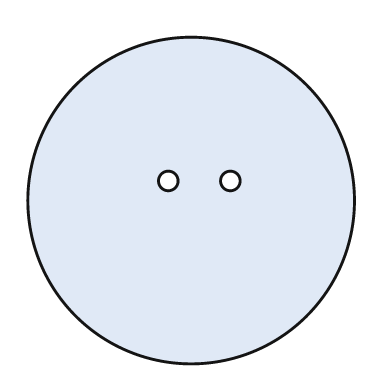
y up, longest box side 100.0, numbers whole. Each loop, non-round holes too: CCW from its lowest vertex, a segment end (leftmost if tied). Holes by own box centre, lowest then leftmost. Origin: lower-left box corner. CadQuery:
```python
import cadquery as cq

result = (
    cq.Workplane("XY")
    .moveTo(50.0, 50.0)
    .circle(50.0)
    .moveTo(43.0, 56.0)
    .circle(3.0)
    .moveTo(62.0, 56.0)
    .circle(3.0)
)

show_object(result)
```